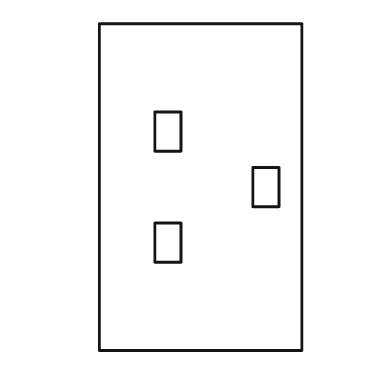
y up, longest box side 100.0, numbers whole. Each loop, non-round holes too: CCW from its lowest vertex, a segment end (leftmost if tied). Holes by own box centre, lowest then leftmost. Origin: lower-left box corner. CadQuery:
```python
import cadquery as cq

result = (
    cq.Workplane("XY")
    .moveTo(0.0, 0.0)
    .lineTo(62.0, 0.0)
    .lineTo(62.0, 100.0)
    .lineTo(0.0, 100.0)
    .close()
    .moveTo(17.0, 27.0)
    .lineTo(25.0, 27.0)
    .lineTo(25.0, 39.0)
    .lineTo(17.0, 39.0)
    .close()
    .moveTo(47.0, 44.0)
    .lineTo(55.0, 44.0)
    .lineTo(55.0, 56.0)
    .lineTo(47.0, 56.0)
    .close()
    .moveTo(17.0, 61.0)
    .lineTo(25.0, 61.0)
    .lineTo(25.0, 73.0)
    .lineTo(17.0, 73.0)
    .close()
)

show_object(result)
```